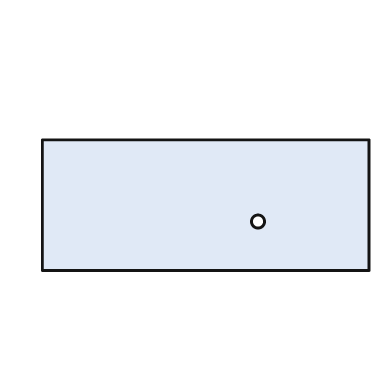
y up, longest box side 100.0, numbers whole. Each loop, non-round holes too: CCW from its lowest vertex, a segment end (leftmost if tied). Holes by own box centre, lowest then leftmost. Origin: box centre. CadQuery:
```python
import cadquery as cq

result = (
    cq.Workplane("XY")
    .moveTo(-50.0, -20.0)
    .lineTo(50.0, -20.0)
    .lineTo(50.0, 20.0)
    .lineTo(-50.0, 20.0)
    .close()
    .moveTo(16.0, -5.0)
    .circle(2.0)
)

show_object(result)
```